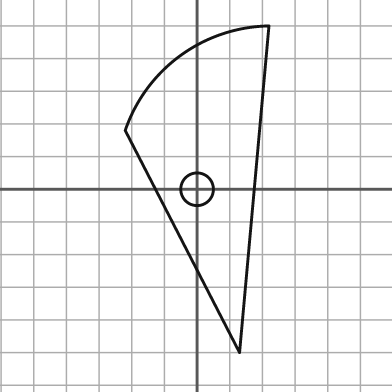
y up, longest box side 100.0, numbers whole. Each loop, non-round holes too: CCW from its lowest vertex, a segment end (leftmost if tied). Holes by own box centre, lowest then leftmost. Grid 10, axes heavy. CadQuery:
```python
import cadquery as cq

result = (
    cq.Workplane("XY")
    .moveTo(13.0, -50.0)
    .lineTo(22.0, 50.0)
    .threePointArc((-5.0, 41.0), (-22.0, 18.0))
    .close()
    .moveTo(0.0, 0.0)
    .circle(5.0)
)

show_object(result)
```